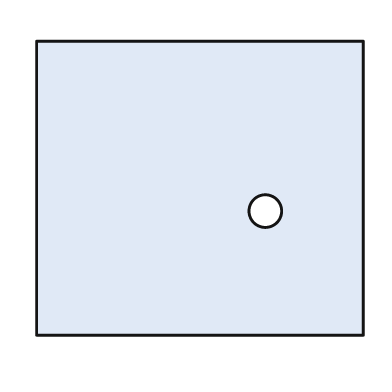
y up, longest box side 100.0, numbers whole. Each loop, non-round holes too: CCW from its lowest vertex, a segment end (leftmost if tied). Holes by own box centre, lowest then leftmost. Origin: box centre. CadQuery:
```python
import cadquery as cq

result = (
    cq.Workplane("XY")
    .moveTo(-50.0, -45.0)
    .lineTo(50.0, -45.0)
    .lineTo(50.0, 45.0)
    .lineTo(-50.0, 45.0)
    .close()
    .moveTo(20.0, -7.0)
    .circle(5.0)
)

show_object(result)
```